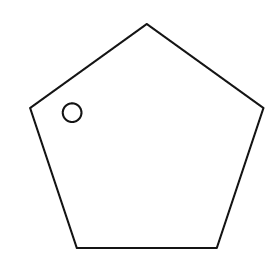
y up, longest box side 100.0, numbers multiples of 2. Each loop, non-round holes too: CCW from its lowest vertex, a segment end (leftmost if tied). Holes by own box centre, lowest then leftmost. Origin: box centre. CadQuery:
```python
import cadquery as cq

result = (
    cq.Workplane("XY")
    .moveTo(-30.0, -48.0)
    .lineTo(30.0, -48.0)
    .lineTo(50.0, 12.0)
    .lineTo(0.0, 48.0)
    .lineTo(-50.0, 12.0)
    .close()
    .moveTo(-32.0, 10.0)
    .circle(4.0)
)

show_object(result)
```